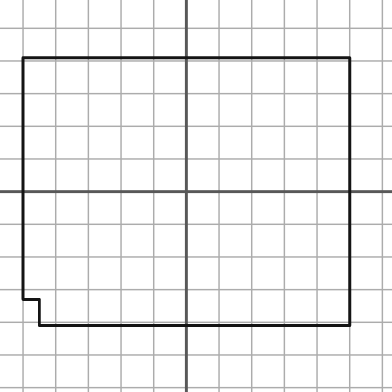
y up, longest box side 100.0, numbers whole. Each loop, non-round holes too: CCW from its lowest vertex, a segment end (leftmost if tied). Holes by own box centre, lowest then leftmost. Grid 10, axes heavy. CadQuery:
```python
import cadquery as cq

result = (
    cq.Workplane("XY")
    .moveTo(-45.0, -41.0)
    .lineTo(50.0, -41.0)
    .lineTo(50.0, 41.0)
    .lineTo(-50.0, 41.0)
    .lineTo(-50.0, -33.0)
    .lineTo(-45.0, -33.0)
    .close()
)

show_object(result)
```